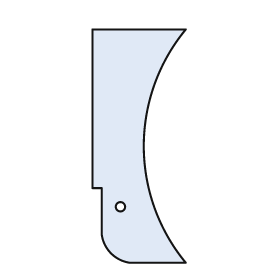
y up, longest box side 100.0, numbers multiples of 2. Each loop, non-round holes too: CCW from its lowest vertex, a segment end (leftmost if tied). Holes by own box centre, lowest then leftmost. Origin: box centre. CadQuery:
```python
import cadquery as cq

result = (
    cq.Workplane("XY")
    .moveTo(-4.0, -50.0)
    .lineTo(20.0, -50.0)
    .threePointArc((2.0, 0.0), (20.0, 50.0))
    .lineTo(-20.0, 50.0)
    .lineTo(-20.0, -18.0)
    .lineTo(-16.0, -18.0)
    .lineTo(-16.0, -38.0)
    .threePointArc((-12.0, -46.0), (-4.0, -50.0))
    .close()
    .moveTo(-8.0, -26.0)
    .circle(2.0)
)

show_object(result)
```